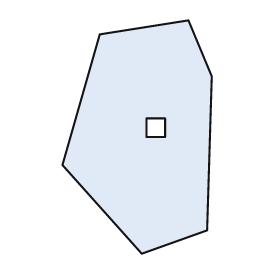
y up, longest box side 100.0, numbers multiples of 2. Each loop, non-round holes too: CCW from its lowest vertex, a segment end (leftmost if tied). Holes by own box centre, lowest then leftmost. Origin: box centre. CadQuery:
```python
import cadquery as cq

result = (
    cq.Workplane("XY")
    .moveTo(2.0, -50.0)
    .lineTo(30.0, -40.0)
    .lineTo(32.0, 26.0)
    .lineTo(22.0, 50.0)
    .lineTo(-16.0, 44.0)
    .lineTo(-32.0, -12.0)
    .close()
    .moveTo(4.0, 0.0)
    .lineTo(12.0, 0.0)
    .lineTo(12.0, 8.0)
    .lineTo(4.0, 8.0)
    .close()
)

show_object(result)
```